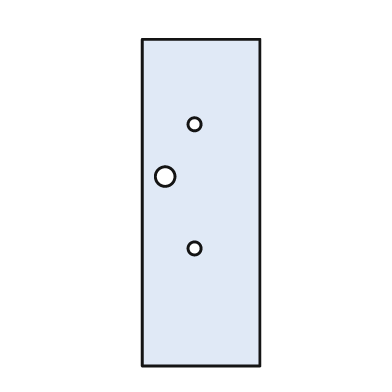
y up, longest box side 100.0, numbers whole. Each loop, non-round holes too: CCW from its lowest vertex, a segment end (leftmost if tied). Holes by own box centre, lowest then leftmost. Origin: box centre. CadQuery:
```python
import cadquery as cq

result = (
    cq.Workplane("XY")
    .moveTo(-18.0, -50.0)
    .lineTo(18.0, -50.0)
    .lineTo(18.0, 50.0)
    .lineTo(-18.0, 50.0)
    .close()
    .moveTo(-2.0, -14.0)
    .circle(2.0)
    .moveTo(-11.0, 8.0)
    .circle(3.0)
    .moveTo(-2.0, 24.0)
    .circle(2.0)
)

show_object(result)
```